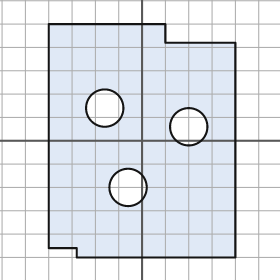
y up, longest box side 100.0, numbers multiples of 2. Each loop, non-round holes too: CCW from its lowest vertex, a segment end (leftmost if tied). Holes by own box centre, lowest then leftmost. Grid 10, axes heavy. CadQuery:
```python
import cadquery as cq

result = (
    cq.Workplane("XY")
    .moveTo(-28.0, -50.0)
    .lineTo(40.0, -50.0)
    .lineTo(40.0, 42.0)
    .lineTo(10.0, 42.0)
    .lineTo(10.0, 50.0)
    .lineTo(-40.0, 50.0)
    .lineTo(-40.0, -46.0)
    .lineTo(-28.0, -46.0)
    .close()
    .moveTo(-6.0, -20.0)
    .circle(8.0)
    .moveTo(20.0, 6.0)
    .circle(8.0)
    .moveTo(-16.0, 14.0)
    .circle(8.0)
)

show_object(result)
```